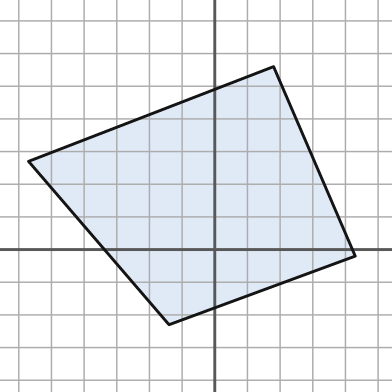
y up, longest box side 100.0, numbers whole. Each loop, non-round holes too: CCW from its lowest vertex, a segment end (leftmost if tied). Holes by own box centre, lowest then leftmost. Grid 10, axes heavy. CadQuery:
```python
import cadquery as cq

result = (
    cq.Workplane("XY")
    .moveTo(-14.0, -23.0)
    .lineTo(43.0, -2.0)
    .lineTo(18.0, 56.0)
    .lineTo(-57.0, 27.0)
    .close()
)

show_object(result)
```